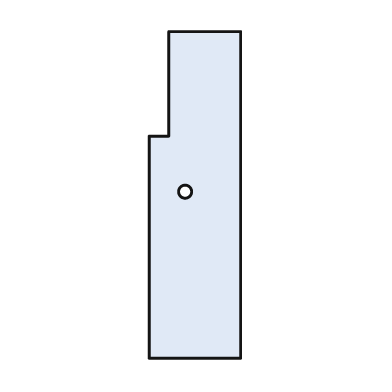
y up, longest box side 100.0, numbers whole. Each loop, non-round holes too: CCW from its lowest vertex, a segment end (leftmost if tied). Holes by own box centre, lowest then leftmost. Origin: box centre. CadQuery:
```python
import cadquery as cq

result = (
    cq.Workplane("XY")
    .moveTo(-14.0, -50.0)
    .lineTo(14.0, -50.0)
    .lineTo(14.0, 50.0)
    .lineTo(-8.0, 50.0)
    .lineTo(-8.0, 18.0)
    .lineTo(-14.0, 18.0)
    .close()
    .moveTo(-3.0, 1.0)
    .circle(2.0)
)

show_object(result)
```